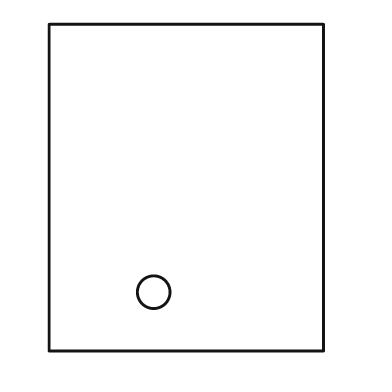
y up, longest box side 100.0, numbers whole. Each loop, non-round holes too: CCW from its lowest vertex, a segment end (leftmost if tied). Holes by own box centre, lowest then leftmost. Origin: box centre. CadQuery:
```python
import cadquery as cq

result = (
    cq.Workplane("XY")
    .moveTo(-42.0, -50.0)
    .lineTo(42.0, -50.0)
    .lineTo(42.0, 50.0)
    .lineTo(-42.0, 50.0)
    .close()
    .moveTo(-10.0, -32.0)
    .circle(5.0)
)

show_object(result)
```